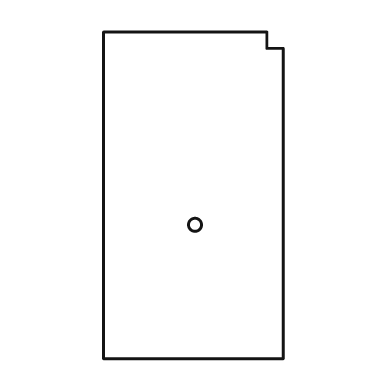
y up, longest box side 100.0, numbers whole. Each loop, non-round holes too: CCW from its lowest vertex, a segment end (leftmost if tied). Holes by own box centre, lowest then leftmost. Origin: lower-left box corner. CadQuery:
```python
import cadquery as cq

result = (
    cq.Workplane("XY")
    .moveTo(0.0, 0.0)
    .lineTo(55.0, 0.0)
    .lineTo(55.0, 95.0)
    .lineTo(50.0, 95.0)
    .lineTo(50.0, 100.0)
    .lineTo(0.0, 100.0)
    .close()
    .moveTo(28.0, 41.0)
    .circle(2.0)
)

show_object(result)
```